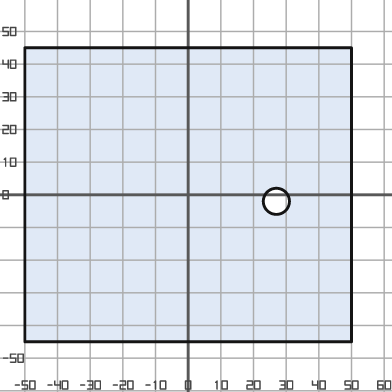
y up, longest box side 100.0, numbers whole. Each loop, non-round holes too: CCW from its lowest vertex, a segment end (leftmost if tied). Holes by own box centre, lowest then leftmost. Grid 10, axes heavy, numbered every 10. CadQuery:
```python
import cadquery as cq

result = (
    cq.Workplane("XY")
    .moveTo(-50.0, -45.0)
    .lineTo(50.0, -45.0)
    .lineTo(50.0, 45.0)
    .lineTo(-50.0, 45.0)
    .close()
    .moveTo(27.0, -2.0)
    .circle(4.0)
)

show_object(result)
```